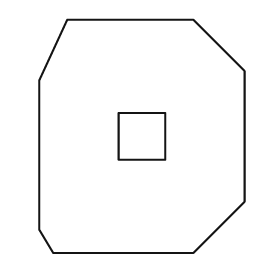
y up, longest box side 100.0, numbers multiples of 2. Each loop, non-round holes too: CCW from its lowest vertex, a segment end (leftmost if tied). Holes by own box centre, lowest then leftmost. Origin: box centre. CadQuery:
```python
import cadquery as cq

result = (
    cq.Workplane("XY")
    .moveTo(-38.0, -50.0)
    .lineTo(22.0, -50.0)
    .lineTo(44.0, -28.0)
    .lineTo(44.0, 28.0)
    .lineTo(22.0, 50.0)
    .lineTo(-32.0, 50.0)
    .lineTo(-44.0, 24.0)
    .lineTo(-44.0, -40.0)
    .close()
    .moveTo(-10.0, -10.0)
    .lineTo(10.0, -10.0)
    .lineTo(10.0, 10.0)
    .lineTo(-10.0, 10.0)
    .close()
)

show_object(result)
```